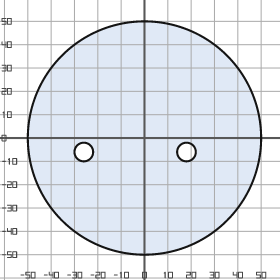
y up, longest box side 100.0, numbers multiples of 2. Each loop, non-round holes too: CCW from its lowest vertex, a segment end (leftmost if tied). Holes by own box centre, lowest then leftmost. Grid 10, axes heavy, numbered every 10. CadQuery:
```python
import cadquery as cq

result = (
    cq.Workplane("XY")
    .moveTo(0.0, 0.0)
    .circle(50.0)
    .moveTo(-26.0, -6.0)
    .circle(4.0)
    .moveTo(18.0, -6.0)
    .circle(4.0)
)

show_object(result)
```